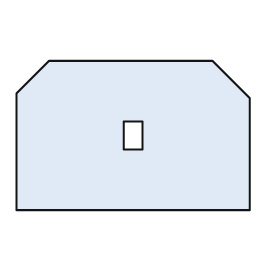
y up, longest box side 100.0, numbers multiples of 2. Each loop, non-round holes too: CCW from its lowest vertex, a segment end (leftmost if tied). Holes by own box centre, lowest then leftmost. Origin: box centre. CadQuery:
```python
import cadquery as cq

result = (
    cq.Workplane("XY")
    .moveTo(-50.0, -32.0)
    .lineTo(50.0, -32.0)
    .lineTo(50.0, 16.0)
    .lineTo(34.0, 32.0)
    .lineTo(-36.0, 32.0)
    .lineTo(-50.0, 18.0)
    .close()
    .moveTo(-4.0, -6.0)
    .lineTo(4.0, -6.0)
    .lineTo(4.0, 6.0)
    .lineTo(-4.0, 6.0)
    .close()
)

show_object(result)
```